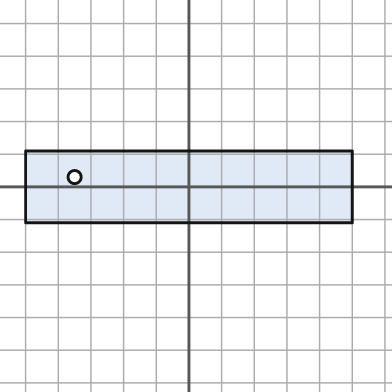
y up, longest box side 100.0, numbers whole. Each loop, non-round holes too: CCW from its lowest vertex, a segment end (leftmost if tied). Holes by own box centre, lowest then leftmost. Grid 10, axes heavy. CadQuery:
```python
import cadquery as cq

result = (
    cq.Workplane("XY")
    .moveTo(-50.0, -11.0)
    .lineTo(50.0, -11.0)
    .lineTo(50.0, 11.0)
    .lineTo(-50.0, 11.0)
    .close()
    .moveTo(-35.0, 3.0)
    .circle(2.0)
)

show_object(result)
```